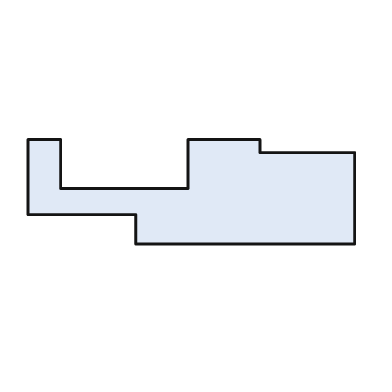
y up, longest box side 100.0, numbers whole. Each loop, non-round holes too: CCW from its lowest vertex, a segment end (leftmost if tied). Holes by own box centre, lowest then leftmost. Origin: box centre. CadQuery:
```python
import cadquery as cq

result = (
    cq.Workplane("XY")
    .moveTo(-17.0, -16.0)
    .lineTo(50.0, -16.0)
    .lineTo(50.0, 12.0)
    .lineTo(21.0, 12.0)
    .lineTo(21.0, 16.0)
    .lineTo(-1.0, 16.0)
    .lineTo(-1.0, 1.0)
    .lineTo(-40.0, 1.0)
    .lineTo(-40.0, 16.0)
    .lineTo(-50.0, 16.0)
    .lineTo(-50.0, -7.0)
    .lineTo(-17.0, -7.0)
    .close()
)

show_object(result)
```